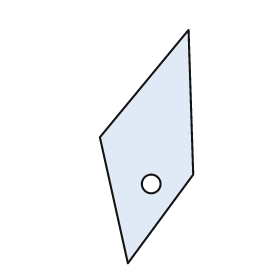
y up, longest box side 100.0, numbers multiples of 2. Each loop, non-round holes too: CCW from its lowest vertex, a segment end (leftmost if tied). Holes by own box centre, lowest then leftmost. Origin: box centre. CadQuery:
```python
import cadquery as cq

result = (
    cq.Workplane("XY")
    .moveTo(-8.0, -50.0)
    .lineTo(20.0, -12.0)
    .lineTo(18.0, 50.0)
    .lineTo(-20.0, 4.0)
    .close()
    .moveTo(2.0, -16.0)
    .circle(4.0)
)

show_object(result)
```